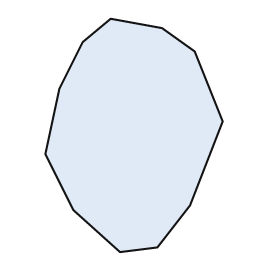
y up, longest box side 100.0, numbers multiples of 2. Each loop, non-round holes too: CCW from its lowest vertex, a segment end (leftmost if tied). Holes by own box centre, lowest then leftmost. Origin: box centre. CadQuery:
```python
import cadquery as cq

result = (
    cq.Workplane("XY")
    .moveTo(-6.0, -50.0)
    .lineTo(10.0, -48.0)
    .lineTo(24.0, -30.0)
    .lineTo(38.0, 6.0)
    .lineTo(26.0, 36.0)
    .lineTo(12.0, 46.0)
    .lineTo(-10.0, 50.0)
    .lineTo(-22.0, 40.0)
    .lineTo(-32.0, 20.0)
    .lineTo(-38.0, -8.0)
    .lineTo(-26.0, -32.0)
    .close()
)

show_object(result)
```